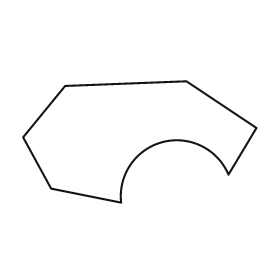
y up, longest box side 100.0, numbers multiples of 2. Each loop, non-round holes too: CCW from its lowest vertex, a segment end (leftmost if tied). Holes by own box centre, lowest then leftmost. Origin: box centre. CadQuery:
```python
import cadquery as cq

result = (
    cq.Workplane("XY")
    .moveTo(-8.0, -26.0)
    .threePointArc((10.0, 0.0), (38.0, -14.0))
    .lineTo(50.0, 6.0)
    .lineTo(20.0, 26.0)
    .lineTo(-32.0, 24.0)
    .lineTo(-50.0, 2.0)
    .lineTo(-38.0, -20.0)
    .close()
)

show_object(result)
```